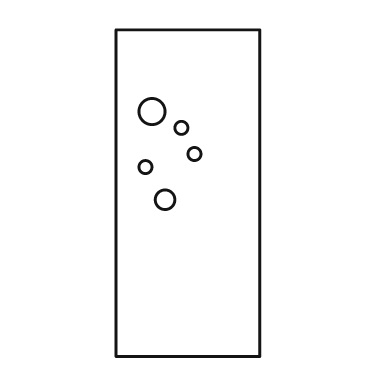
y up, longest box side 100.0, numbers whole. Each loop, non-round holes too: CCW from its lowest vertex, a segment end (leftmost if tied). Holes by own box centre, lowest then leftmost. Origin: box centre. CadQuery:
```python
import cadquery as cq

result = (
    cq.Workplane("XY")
    .moveTo(-22.0, -50.0)
    .lineTo(22.0, -50.0)
    .lineTo(22.0, 50.0)
    .lineTo(-22.0, 50.0)
    .close()
    .moveTo(-7.0, -2.0)
    .circle(3.0)
    .moveTo(-13.0, 8.0)
    .circle(2.0)
    .moveTo(2.0, 12.0)
    .circle(2.0)
    .moveTo(-2.0, 20.0)
    .circle(2.0)
    .moveTo(-11.0, 25.0)
    .circle(4.0)
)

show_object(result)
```